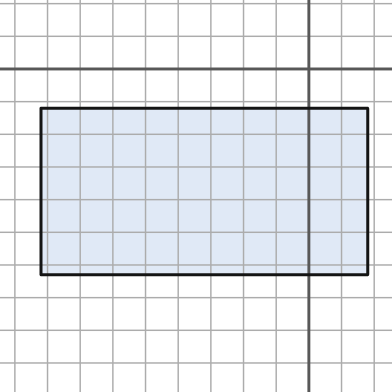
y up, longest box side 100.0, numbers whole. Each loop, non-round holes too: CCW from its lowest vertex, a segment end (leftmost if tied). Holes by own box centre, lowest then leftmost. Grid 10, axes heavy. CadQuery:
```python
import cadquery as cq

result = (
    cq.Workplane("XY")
    .moveTo(-82.0, -63.0)
    .lineTo(18.0, -63.0)
    .lineTo(18.0, -12.0)
    .lineTo(-82.0, -12.0)
    .close()
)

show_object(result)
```